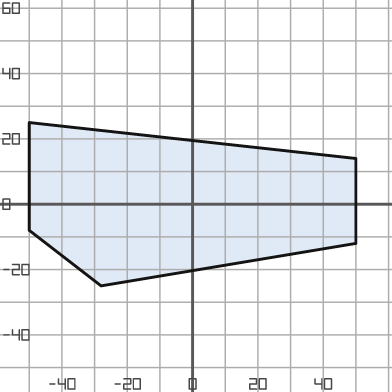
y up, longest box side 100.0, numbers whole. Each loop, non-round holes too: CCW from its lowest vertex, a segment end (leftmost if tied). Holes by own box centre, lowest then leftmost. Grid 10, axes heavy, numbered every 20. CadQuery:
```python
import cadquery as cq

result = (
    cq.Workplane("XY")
    .moveTo(-28.0, -25.0)
    .lineTo(50.0, -12.0)
    .lineTo(50.0, 14.0)
    .lineTo(-50.0, 25.0)
    .lineTo(-50.0, -8.0)
    .close()
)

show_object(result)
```